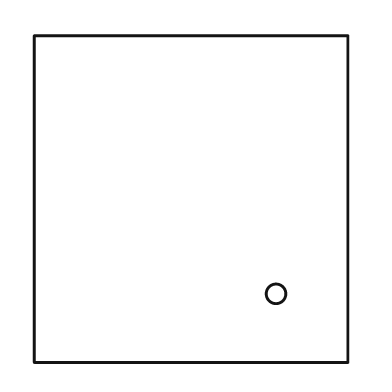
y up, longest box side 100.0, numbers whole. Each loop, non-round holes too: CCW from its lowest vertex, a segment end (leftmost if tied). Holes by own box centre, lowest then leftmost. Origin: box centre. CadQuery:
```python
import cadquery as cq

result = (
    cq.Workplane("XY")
    .moveTo(-48.0, -50.0)
    .lineTo(48.0, -50.0)
    .lineTo(48.0, 50.0)
    .lineTo(-48.0, 50.0)
    .close()
    .moveTo(26.0, -29.0)
    .circle(3.0)
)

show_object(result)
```